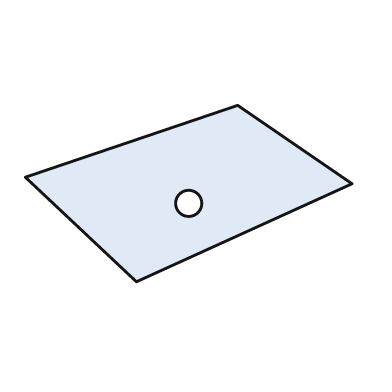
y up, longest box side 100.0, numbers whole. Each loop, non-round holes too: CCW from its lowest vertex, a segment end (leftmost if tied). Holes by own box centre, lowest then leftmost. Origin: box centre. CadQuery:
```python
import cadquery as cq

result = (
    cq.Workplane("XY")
    .moveTo(-16.0, -27.0)
    .lineTo(50.0, 3.0)
    .lineTo(15.0, 27.0)
    .lineTo(-50.0, 5.0)
    .close()
    .moveTo(0.0, -3.0)
    .circle(4.0)
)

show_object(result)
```